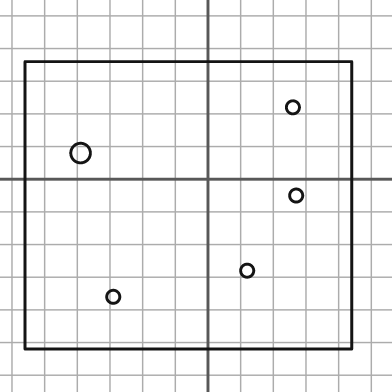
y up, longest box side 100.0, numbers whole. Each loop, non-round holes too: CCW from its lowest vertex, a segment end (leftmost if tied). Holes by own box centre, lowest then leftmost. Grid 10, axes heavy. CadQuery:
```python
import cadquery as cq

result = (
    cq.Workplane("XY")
    .moveTo(-56.0, -52.0)
    .lineTo(44.0, -52.0)
    .lineTo(44.0, 36.0)
    .lineTo(-56.0, 36.0)
    .close()
    .moveTo(-29.0, -36.0)
    .circle(2.0)
    .moveTo(12.0, -28.0)
    .circle(2.0)
    .moveTo(27.0, -5.0)
    .circle(2.0)
    .moveTo(-39.0, 8.0)
    .circle(3.0)
    .moveTo(26.0, 22.0)
    .circle(2.0)
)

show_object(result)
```